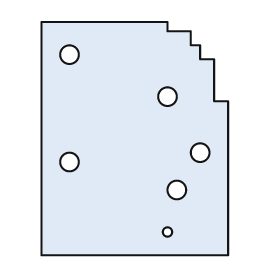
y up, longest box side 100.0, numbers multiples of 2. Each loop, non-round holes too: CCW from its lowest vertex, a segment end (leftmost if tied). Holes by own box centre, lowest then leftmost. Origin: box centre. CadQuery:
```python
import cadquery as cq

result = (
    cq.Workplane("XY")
    .moveTo(-40.0, -50.0)
    .lineTo(40.0, -50.0)
    .lineTo(40.0, 16.0)
    .lineTo(34.0, 16.0)
    .lineTo(34.0, 34.0)
    .lineTo(28.0, 34.0)
    .lineTo(28.0, 40.0)
    .lineTo(24.0, 40.0)
    .lineTo(24.0, 46.0)
    .lineTo(14.0, 46.0)
    .lineTo(14.0, 50.0)
    .lineTo(-40.0, 50.0)
    .close()
    .moveTo(14.0, -40.0)
    .circle(2.0)
    .moveTo(18.0, -22.0)
    .circle(4.0)
    .moveTo(-28.0, -10.0)
    .circle(4.0)
    .moveTo(28.0, -6.0)
    .circle(4.0)
    .moveTo(14.0, 18.0)
    .circle(4.0)
    .moveTo(-28.0, 36.0)
    .circle(4.0)
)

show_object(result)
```